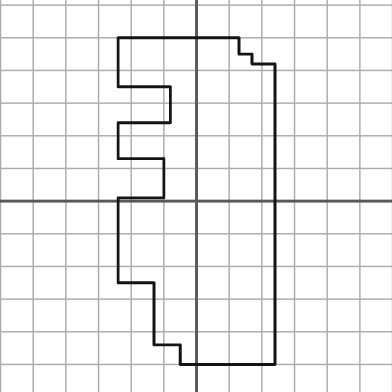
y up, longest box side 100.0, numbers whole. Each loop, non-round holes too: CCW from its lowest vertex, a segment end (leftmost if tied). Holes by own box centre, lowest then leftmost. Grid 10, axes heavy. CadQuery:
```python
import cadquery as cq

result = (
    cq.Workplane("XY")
    .moveTo(-5.0, -50.0)
    .lineTo(24.0, -50.0)
    .lineTo(24.0, 42.0)
    .lineTo(17.0, 42.0)
    .lineTo(17.0, 45.0)
    .lineTo(13.0, 45.0)
    .lineTo(13.0, 50.0)
    .lineTo(-24.0, 50.0)
    .lineTo(-24.0, 35.0)
    .lineTo(-8.0, 35.0)
    .lineTo(-8.0, 24.0)
    .lineTo(-24.0, 24.0)
    .lineTo(-24.0, 13.0)
    .lineTo(-10.0, 13.0)
    .lineTo(-10.0, 1.0)
    .lineTo(-24.0, 1.0)
    .lineTo(-24.0, -25.0)
    .lineTo(-13.0, -25.0)
    .lineTo(-13.0, -44.0)
    .lineTo(-5.0, -44.0)
    .close()
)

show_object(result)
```